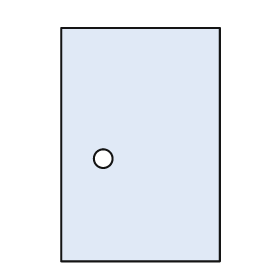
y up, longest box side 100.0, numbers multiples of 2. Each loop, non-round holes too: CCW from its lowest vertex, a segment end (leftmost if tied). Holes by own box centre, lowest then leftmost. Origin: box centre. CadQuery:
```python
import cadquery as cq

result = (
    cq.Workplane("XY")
    .moveTo(-34.0, -50.0)
    .lineTo(34.0, -50.0)
    .lineTo(34.0, 50.0)
    .lineTo(-34.0, 50.0)
    .close()
    .moveTo(-16.0, -6.0)
    .circle(4.0)
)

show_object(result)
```